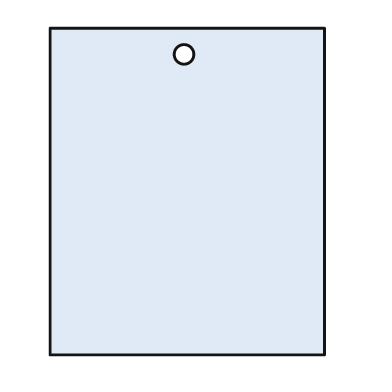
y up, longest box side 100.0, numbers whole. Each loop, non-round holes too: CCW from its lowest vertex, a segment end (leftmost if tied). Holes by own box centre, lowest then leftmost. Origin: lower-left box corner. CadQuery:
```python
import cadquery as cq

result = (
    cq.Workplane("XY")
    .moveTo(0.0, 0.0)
    .lineTo(84.0, 0.0)
    .lineTo(84.0, 100.0)
    .lineTo(0.0, 100.0)
    .close()
    .moveTo(41.0, 92.0)
    .circle(3.0)
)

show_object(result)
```